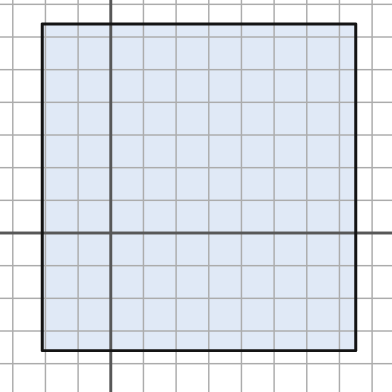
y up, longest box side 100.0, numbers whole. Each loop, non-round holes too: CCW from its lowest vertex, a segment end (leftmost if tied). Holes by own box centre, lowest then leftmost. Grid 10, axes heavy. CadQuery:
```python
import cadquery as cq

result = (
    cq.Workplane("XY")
    .moveTo(-21.0, -36.0)
    .lineTo(75.0, -36.0)
    .lineTo(75.0, 64.0)
    .lineTo(-21.0, 64.0)
    .close()
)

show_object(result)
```